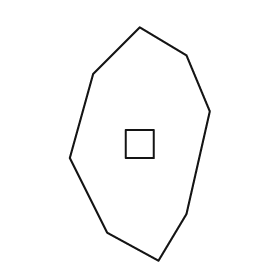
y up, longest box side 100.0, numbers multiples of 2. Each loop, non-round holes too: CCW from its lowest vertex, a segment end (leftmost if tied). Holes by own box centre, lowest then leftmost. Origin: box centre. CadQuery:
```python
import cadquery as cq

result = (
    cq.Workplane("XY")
    .moveTo(8.0, -50.0)
    .lineTo(20.0, -30.0)
    .lineTo(30.0, 14.0)
    .lineTo(20.0, 38.0)
    .lineTo(0.0, 50.0)
    .lineTo(-20.0, 30.0)
    .lineTo(-30.0, -6.0)
    .lineTo(-14.0, -38.0)
    .close()
    .moveTo(-6.0, -6.0)
    .lineTo(6.0, -6.0)
    .lineTo(6.0, 6.0)
    .lineTo(-6.0, 6.0)
    .close()
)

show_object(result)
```